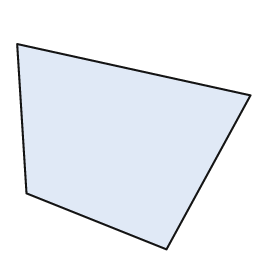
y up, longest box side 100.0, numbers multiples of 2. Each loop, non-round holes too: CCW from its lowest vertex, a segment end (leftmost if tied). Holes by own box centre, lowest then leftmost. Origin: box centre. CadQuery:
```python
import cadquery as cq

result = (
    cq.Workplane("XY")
    .moveTo(14.0, -44.0)
    .lineTo(50.0, 22.0)
    .lineTo(-50.0, 44.0)
    .lineTo(-46.0, -20.0)
    .close()
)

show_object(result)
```